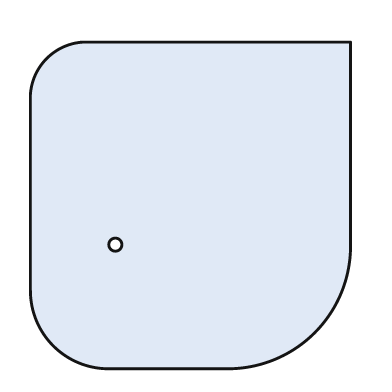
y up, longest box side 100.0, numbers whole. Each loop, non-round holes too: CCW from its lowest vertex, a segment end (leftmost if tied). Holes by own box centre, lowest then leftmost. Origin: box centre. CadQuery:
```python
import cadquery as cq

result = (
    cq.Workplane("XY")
    .moveTo(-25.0, -50.0)
    .lineTo(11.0, -50.0)
    .threePointArc((38.0, -39.0), (49.0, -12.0))
    .lineTo(49.0, 50.0)
    .lineTo(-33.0, 50.0)
    .threePointArc((-44.0, 45.0), (-49.0, 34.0))
    .lineTo(-49.0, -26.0)
    .threePointArc((-42.0, -43.0), (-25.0, -50.0))
    .close()
    .moveTo(-23.0, -12.0)
    .circle(2.0)
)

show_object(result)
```